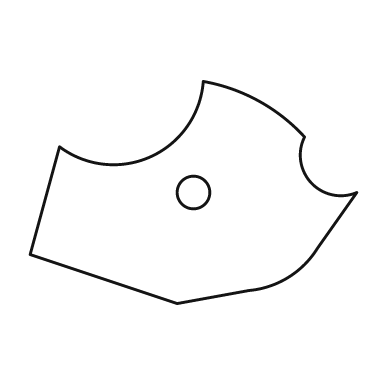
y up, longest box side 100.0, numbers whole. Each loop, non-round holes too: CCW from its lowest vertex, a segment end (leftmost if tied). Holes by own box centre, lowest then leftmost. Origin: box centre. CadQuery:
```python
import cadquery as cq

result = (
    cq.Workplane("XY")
    .moveTo(-5.0, -34.0)
    .lineTo(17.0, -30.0)
    .threePointArc((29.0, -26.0), (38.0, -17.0))
    .lineTo(50.0, 0.0)
    .threePointArc((36.0, 3.0), (34.0, 17.0))
    .threePointArc((20.0, 28.0), (3.0, 34.0))
    .threePointArc((-13.0, 11.0), (-41.0, 14.0))
    .lineTo(-50.0, -19.0)
    .close()
    .moveTo(0.0, 0.0)
    .circle(5.0)
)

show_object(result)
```